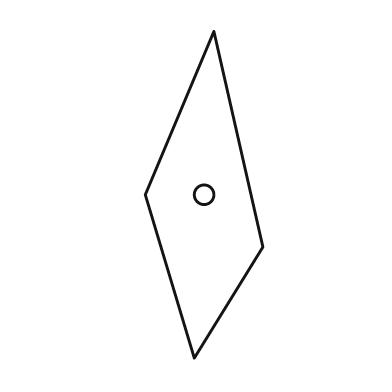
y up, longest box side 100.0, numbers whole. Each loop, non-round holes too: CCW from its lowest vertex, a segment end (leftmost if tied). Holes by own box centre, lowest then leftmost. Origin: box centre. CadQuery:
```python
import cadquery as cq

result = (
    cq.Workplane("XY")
    .moveTo(-3.0, -50.0)
    .lineTo(18.0, -16.0)
    .lineTo(3.0, 50.0)
    .lineTo(-18.0, 0.0)
    .close()
    .moveTo(0.0, 0.0)
    .circle(3.0)
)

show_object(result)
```